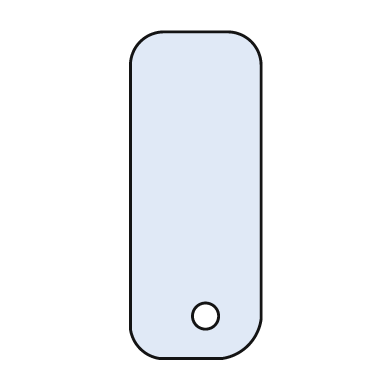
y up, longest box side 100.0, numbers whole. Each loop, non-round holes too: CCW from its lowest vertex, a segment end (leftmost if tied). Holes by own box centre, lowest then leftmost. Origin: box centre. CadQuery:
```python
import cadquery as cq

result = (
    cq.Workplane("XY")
    .moveTo(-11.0, -50.0)
    .lineTo(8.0, -50.0)
    .threePointArc((16.0, -46.0), (20.0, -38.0))
    .lineTo(20.0, 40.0)
    .threePointArc((17.0, 47.0), (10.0, 50.0))
    .lineTo(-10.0, 50.0)
    .threePointArc((-17.0, 47.0), (-20.0, 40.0))
    .lineTo(-20.0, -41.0)
    .threePointArc((-17.0, -47.0), (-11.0, -50.0))
    .close()
    .moveTo(3.0, -37.0)
    .circle(4.0)
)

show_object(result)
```